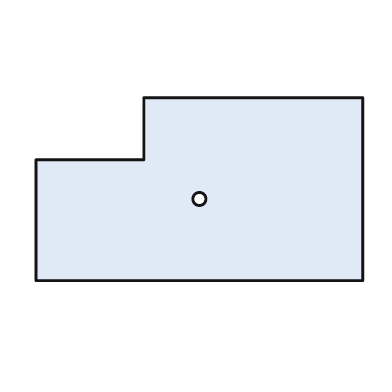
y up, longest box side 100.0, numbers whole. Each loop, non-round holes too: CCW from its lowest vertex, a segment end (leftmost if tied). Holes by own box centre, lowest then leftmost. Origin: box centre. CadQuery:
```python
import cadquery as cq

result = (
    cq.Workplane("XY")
    .moveTo(-50.0, -28.0)
    .lineTo(50.0, -28.0)
    .lineTo(50.0, 28.0)
    .lineTo(-17.0, 28.0)
    .lineTo(-17.0, 9.0)
    .lineTo(-50.0, 9.0)
    .close()
    .moveTo(0.0, -3.0)
    .circle(2.0)
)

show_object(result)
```